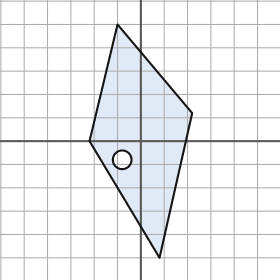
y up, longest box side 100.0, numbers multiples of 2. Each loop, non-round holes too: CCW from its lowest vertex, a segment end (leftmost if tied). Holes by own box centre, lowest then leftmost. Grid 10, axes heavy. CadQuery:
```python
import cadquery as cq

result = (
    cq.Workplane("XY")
    .moveTo(8.0, -50.0)
    .lineTo(22.0, 12.0)
    .lineTo(-10.0, 50.0)
    .lineTo(-22.0, 0.0)
    .close()
    .moveTo(-8.0, -8.0)
    .circle(4.0)
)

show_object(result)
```